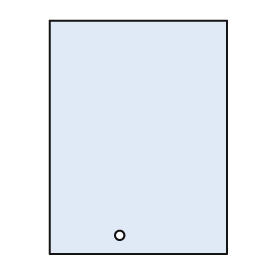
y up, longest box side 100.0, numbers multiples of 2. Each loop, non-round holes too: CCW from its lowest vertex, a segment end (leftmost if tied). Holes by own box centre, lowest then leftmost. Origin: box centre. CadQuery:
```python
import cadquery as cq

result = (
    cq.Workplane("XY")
    .moveTo(-38.0, -50.0)
    .lineTo(38.0, -50.0)
    .lineTo(38.0, 50.0)
    .lineTo(-38.0, 50.0)
    .close()
    .moveTo(-8.0, -42.0)
    .circle(2.0)
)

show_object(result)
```